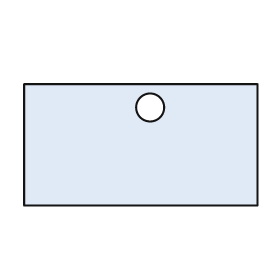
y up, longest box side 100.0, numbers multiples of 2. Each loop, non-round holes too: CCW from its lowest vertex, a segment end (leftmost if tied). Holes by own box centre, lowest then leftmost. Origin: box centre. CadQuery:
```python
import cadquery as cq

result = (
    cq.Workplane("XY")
    .moveTo(-50.0, -26.0)
    .lineTo(50.0, -26.0)
    .lineTo(50.0, 26.0)
    .lineTo(-50.0, 26.0)
    .close()
    .moveTo(4.0, 16.0)
    .circle(6.0)
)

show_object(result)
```